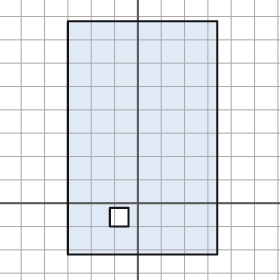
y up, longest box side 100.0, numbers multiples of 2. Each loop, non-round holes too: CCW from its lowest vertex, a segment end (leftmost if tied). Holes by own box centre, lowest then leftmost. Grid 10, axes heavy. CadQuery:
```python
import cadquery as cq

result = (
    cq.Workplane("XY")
    .moveTo(-30.0, -22.0)
    .lineTo(34.0, -22.0)
    .lineTo(34.0, 78.0)
    .lineTo(-30.0, 78.0)
    .close()
    .moveTo(-12.0, -10.0)
    .lineTo(-4.0, -10.0)
    .lineTo(-4.0, -2.0)
    .lineTo(-12.0, -2.0)
    .close()
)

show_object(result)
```